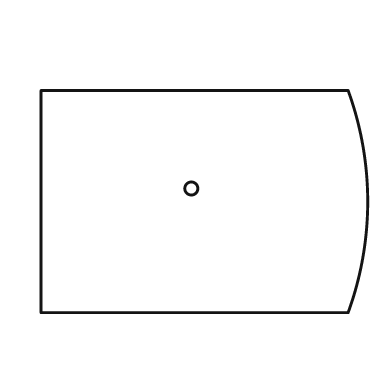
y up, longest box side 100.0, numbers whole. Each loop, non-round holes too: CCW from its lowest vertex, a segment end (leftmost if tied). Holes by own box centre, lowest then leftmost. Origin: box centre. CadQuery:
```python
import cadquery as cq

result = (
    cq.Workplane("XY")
    .moveTo(-50.0, -34.0)
    .lineTo(44.0, -34.0)
    .threePointArc((50.0, 0.0), (44.0, 34.0))
    .lineTo(-50.0, 34.0)
    .close()
    .moveTo(-4.0, 4.0)
    .circle(2.0)
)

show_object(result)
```